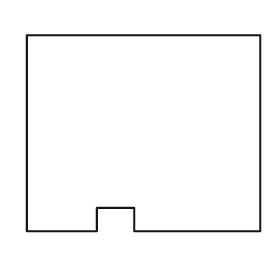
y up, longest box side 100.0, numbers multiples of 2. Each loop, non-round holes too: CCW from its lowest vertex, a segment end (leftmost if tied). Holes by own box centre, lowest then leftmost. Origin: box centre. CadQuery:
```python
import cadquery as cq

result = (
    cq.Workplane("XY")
    .moveTo(-50.0, -42.0)
    .lineTo(-20.0, -42.0)
    .lineTo(-20.0, -32.0)
    .lineTo(-4.0, -32.0)
    .lineTo(-4.0, -42.0)
    .lineTo(50.0, -42.0)
    .lineTo(50.0, 42.0)
    .lineTo(-50.0, 42.0)
    .close()
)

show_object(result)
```